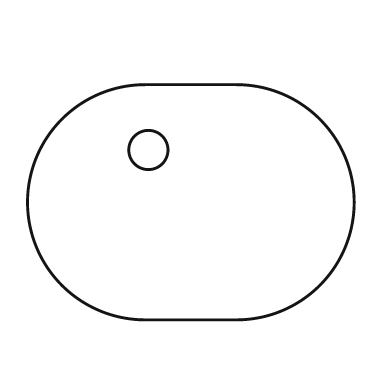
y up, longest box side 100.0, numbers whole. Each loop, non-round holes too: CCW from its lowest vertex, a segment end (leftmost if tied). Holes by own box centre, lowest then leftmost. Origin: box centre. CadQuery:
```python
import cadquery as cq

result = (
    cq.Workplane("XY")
    .moveTo(-14.0, -36.0)
    .lineTo(14.0, -36.0)
    .threePointArc((50.0, 0.0), (14.0, 36.0))
    .lineTo(-14.0, 36.0)
    .threePointArc((-50.0, 0.0), (-14.0, -36.0))
    .close()
    .moveTo(-13.0, 16.0)
    .circle(6.0)
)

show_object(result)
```